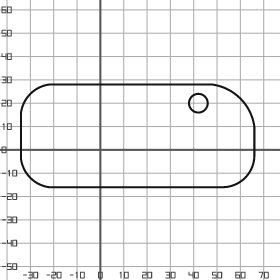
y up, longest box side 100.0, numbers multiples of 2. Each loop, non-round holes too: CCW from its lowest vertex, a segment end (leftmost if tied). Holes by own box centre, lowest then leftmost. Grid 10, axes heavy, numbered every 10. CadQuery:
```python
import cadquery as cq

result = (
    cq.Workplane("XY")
    .moveTo(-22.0, -16.0)
    .lineTo(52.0, -16.0)
    .threePointArc((62.0, -12.0), (66.0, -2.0))
    .lineTo(66.0, 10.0)
    .threePointArc((60.0, 22.0), (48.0, 28.0))
    .lineTo(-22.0, 28.0)
    .threePointArc((-30.0, 24.0), (-34.0, 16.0))
    .lineTo(-34.0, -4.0)
    .threePointArc((-30.0, -12.0), (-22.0, -16.0))
    .close()
    .moveTo(42.0, 20.0)
    .circle(4.0)
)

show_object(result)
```